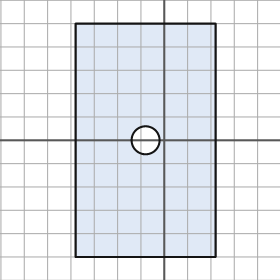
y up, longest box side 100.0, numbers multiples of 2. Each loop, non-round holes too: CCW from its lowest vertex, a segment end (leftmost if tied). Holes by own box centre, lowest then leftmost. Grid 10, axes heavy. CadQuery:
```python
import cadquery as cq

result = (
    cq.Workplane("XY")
    .moveTo(-38.0, -50.0)
    .lineTo(22.0, -50.0)
    .lineTo(22.0, 50.0)
    .lineTo(-38.0, 50.0)
    .close()
    .moveTo(-8.0, 0.0)
    .circle(6.0)
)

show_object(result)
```